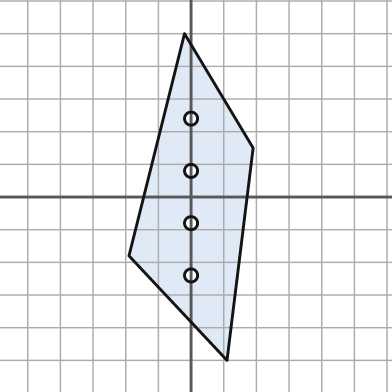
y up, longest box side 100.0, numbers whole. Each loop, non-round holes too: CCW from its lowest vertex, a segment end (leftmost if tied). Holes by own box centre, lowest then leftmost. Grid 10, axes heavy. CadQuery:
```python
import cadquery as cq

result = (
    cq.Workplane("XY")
    .moveTo(11.0, -50.0)
    .lineTo(19.0, 15.0)
    .lineTo(-2.0, 50.0)
    .lineTo(-19.0, -18.0)
    .close()
    .moveTo(0.0, -24.0)
    .circle(2.0)
    .moveTo(0.0, -8.0)
    .circle(2.0)
    .moveTo(0.0, 8.0)
    .circle(2.0)
    .moveTo(0.0, 24.0)
    .circle(2.0)
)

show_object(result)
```